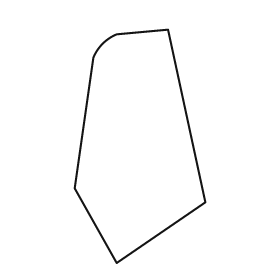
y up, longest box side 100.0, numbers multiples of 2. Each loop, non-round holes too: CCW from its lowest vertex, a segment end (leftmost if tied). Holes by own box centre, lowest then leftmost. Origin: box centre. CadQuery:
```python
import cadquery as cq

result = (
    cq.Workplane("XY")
    .moveTo(-10.0, -50.0)
    .lineTo(28.0, -24.0)
    .lineTo(12.0, 50.0)
    .lineTo(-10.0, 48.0)
    .threePointArc((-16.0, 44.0), (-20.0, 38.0))
    .lineTo(-28.0, -18.0)
    .close()
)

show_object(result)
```